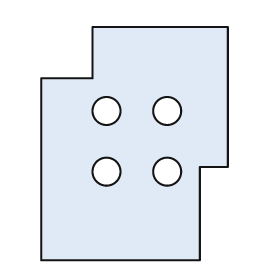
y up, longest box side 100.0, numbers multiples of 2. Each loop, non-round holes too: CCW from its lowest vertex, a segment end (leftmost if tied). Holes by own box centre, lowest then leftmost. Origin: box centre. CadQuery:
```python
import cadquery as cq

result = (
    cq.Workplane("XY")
    .moveTo(-40.0, -50.0)
    .lineTo(28.0, -50.0)
    .lineTo(28.0, -10.0)
    .lineTo(40.0, -10.0)
    .lineTo(40.0, 50.0)
    .lineTo(-18.0, 50.0)
    .lineTo(-18.0, 28.0)
    .lineTo(-40.0, 28.0)
    .close()
    .moveTo(-12.0, -12.0)
    .circle(6.0)
    .moveTo(14.0, -12.0)
    .circle(6.0)
    .moveTo(-12.0, 14.0)
    .circle(6.0)
    .moveTo(14.0, 14.0)
    .circle(6.0)
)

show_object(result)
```